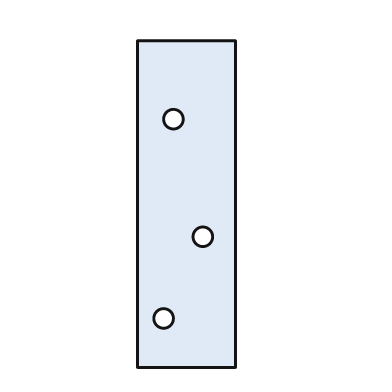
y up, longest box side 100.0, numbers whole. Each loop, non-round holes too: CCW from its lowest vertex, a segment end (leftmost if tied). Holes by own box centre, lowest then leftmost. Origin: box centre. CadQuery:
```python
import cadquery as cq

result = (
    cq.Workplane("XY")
    .moveTo(-15.0, -50.0)
    .lineTo(15.0, -50.0)
    .lineTo(15.0, 50.0)
    .lineTo(-15.0, 50.0)
    .close()
    .moveTo(-7.0, -35.0)
    .circle(3.0)
    .moveTo(5.0, -10.0)
    .circle(3.0)
    .moveTo(-4.0, 26.0)
    .circle(3.0)
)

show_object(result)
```